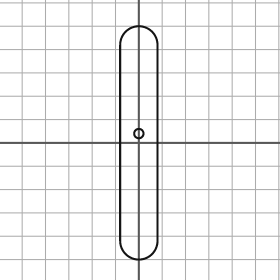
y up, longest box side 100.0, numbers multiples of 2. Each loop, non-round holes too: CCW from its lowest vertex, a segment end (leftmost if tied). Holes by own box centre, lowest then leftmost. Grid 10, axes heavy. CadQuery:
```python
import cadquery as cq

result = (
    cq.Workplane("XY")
    .moveTo(-8.0, -42.0)
    .threePointArc((0.0, -50.0), (8.0, -42.0))
    .lineTo(8.0, 42.0)
    .threePointArc((0.0, 50.0), (-8.0, 42.0))
    .close()
    .moveTo(0.0, 4.0)
    .circle(2.0)
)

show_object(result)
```